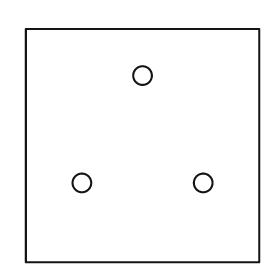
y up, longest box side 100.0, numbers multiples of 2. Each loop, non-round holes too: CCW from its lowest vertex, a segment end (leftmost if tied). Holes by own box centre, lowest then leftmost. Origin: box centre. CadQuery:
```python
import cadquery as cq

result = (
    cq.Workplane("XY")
    .moveTo(-50.0, -50.0)
    .lineTo(50.0, -50.0)
    .lineTo(50.0, 50.0)
    .lineTo(-50.0, 50.0)
    .close()
    .moveTo(-26.0, -16.0)
    .circle(4.0)
    .moveTo(26.0, -16.0)
    .circle(4.0)
    .moveTo(0.0, 30.0)
    .circle(4.0)
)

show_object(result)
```